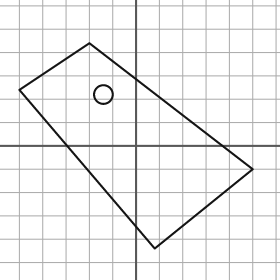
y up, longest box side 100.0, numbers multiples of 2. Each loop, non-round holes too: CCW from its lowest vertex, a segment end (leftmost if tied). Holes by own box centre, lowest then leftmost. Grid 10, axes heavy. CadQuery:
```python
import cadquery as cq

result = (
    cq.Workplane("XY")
    .moveTo(8.0, -44.0)
    .lineTo(50.0, -10.0)
    .lineTo(-20.0, 44.0)
    .lineTo(-50.0, 24.0)
    .close()
    .moveTo(-14.0, 22.0)
    .circle(4.0)
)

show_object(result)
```